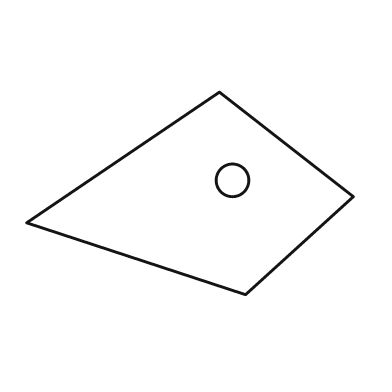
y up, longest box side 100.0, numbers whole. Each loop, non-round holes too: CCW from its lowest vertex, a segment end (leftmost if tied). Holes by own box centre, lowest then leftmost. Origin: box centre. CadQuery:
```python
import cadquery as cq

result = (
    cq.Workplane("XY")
    .moveTo(17.0, -31.0)
    .lineTo(50.0, -1.0)
    .lineTo(9.0, 31.0)
    .lineTo(-50.0, -9.0)
    .close()
    .moveTo(13.0, 4.0)
    .circle(5.0)
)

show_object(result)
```